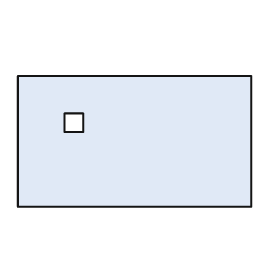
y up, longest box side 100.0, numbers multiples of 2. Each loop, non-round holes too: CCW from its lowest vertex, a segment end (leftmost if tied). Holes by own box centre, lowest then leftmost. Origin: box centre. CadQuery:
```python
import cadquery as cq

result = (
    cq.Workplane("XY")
    .moveTo(-50.0, -28.0)
    .lineTo(50.0, -28.0)
    .lineTo(50.0, 28.0)
    .lineTo(-50.0, 28.0)
    .close()
    .moveTo(-30.0, 4.0)
    .lineTo(-22.0, 4.0)
    .lineTo(-22.0, 12.0)
    .lineTo(-30.0, 12.0)
    .close()
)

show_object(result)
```